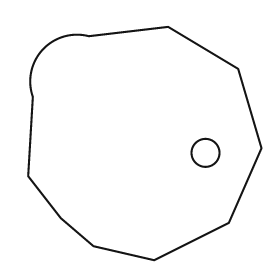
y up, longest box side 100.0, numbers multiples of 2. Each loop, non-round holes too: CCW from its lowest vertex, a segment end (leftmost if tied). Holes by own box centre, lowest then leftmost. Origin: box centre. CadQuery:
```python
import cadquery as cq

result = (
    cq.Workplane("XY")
    .moveTo(4.0, -50.0)
    .lineTo(36.0, -34.0)
    .lineTo(50.0, -2.0)
    .lineTo(40.0, 32.0)
    .lineTo(10.0, 50.0)
    .lineTo(-24.0, 46.0)
    .threePointArc((-44.0, 40.0), (-48.0, 20.0))
    .lineTo(-50.0, -14.0)
    .lineTo(-36.0, -32.0)
    .lineTo(-22.0, -44.0)
    .close()
    .moveTo(26.0, -4.0)
    .circle(6.0)
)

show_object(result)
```